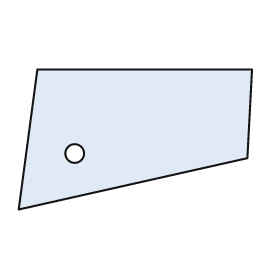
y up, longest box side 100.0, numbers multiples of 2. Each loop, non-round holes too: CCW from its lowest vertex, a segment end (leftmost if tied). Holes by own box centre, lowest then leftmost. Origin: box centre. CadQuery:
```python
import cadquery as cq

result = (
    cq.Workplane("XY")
    .moveTo(-50.0, -30.0)
    .lineTo(48.0, -8.0)
    .lineTo(50.0, 30.0)
    .lineTo(-42.0, 30.0)
    .close()
    .moveTo(-26.0, -6.0)
    .circle(4.0)
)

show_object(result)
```